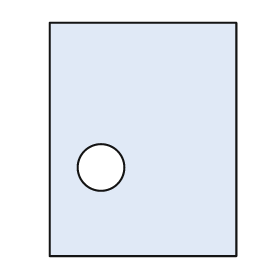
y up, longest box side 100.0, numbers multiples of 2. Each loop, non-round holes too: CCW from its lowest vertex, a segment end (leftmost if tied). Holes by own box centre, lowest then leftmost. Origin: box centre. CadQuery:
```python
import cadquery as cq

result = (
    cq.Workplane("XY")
    .moveTo(-40.0, -50.0)
    .lineTo(40.0, -50.0)
    .lineTo(40.0, 50.0)
    .lineTo(-40.0, 50.0)
    .close()
    .moveTo(-18.0, -12.0)
    .circle(10.0)
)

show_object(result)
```